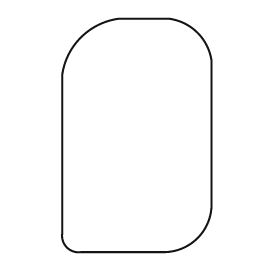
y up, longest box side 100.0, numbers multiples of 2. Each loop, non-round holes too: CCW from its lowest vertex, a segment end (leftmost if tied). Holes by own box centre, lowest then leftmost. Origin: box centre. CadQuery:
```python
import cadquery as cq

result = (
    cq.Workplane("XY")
    .moveTo(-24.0, -50.0)
    .lineTo(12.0, -50.0)
    .threePointArc((26.0, -44.0), (32.0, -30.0))
    .lineTo(32.0, 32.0)
    .threePointArc((26.0, 44.0), (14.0, 50.0))
    .lineTo(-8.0, 50.0)
    .threePointArc((-24.0, 42.0), (-32.0, 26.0))
    .lineTo(-32.0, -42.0)
    .threePointArc((-30.0, -48.0), (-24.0, -50.0))
    .close()
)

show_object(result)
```